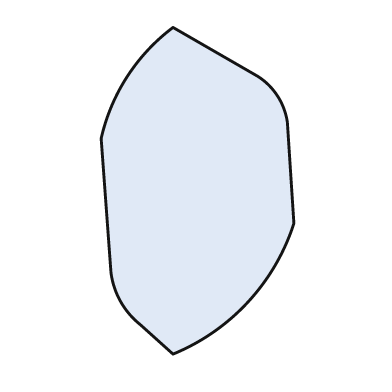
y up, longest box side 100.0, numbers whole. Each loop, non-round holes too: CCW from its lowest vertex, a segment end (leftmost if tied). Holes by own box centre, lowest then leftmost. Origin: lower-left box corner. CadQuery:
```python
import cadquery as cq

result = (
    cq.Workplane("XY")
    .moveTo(22.0, 0.0)
    .threePointArc((45.0, 16.0), (59.0, 40.0))
    .lineTo(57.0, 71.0)
    .threePointArc((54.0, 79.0), (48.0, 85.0))
    .lineTo(22.0, 100.0)
    .threePointArc((8.0, 85.0), (0.0, 66.0))
    .lineTo(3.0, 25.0)
    .threePointArc((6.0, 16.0), (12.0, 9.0))
    .close()
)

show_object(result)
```